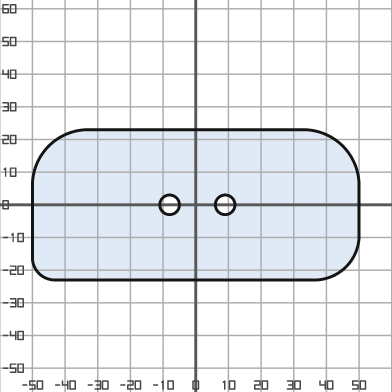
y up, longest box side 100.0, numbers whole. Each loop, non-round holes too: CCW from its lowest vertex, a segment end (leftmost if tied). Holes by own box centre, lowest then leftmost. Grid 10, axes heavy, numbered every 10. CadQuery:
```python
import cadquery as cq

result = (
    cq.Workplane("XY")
    .moveTo(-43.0, -23.0)
    .lineTo(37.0, -23.0)
    .threePointArc((46.0, -19.0), (50.0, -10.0))
    .lineTo(50.0, 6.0)
    .threePointArc((45.0, 18.0), (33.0, 23.0))
    .lineTo(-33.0, 23.0)
    .threePointArc((-45.0, 18.0), (-50.0, 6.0))
    .lineTo(-50.0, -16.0)
    .threePointArc((-48.0, -21.0), (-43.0, -23.0))
    .close()
    .moveTo(-8.0, 0.0)
    .circle(3.0)
    .moveTo(9.0, 0.0)
    .circle(3.0)
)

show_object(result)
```